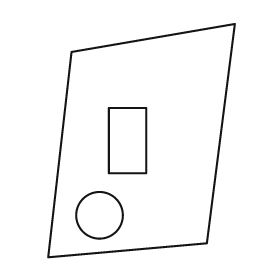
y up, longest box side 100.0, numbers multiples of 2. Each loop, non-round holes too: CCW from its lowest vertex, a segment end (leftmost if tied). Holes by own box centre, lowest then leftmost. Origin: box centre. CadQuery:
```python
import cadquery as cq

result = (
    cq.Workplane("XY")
    .moveTo(-40.0, -50.0)
    .lineTo(28.0, -44.0)
    .lineTo(40.0, 50.0)
    .lineTo(-30.0, 38.0)
    .close()
    .moveTo(-18.0, -32.0)
    .circle(10.0)
    .moveTo(-14.0, -14.0)
    .lineTo(2.0, -14.0)
    .lineTo(2.0, 14.0)
    .lineTo(-14.0, 14.0)
    .close()
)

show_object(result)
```